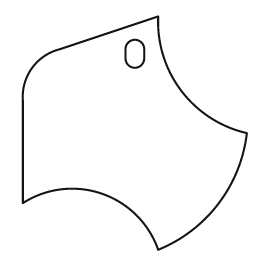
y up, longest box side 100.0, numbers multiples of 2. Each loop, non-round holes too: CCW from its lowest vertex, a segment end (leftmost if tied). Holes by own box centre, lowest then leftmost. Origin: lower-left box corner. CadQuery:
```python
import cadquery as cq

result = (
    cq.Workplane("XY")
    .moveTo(58.0, 0.0)
    .threePointArc((84.0, 20.0), (96.0, 50.0))
    .threePointArc((68.0, 68.0), (58.0, 100.0))
    .lineTo(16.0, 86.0)
    .threePointArc((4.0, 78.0), (0.0, 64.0))
    .lineTo(0.0, 20.0)
    .threePointArc((34.0, 24.0), (58.0, 0.0))
    .close()
    .moveTo(44.0, 82.0)
    .threePointArc((48.0, 78.0), (52.0, 82.0))
    .lineTo(52.0, 86.0)
    .threePointArc((48.0, 90.0), (44.0, 86.0))
    .close()
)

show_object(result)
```